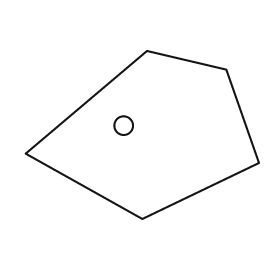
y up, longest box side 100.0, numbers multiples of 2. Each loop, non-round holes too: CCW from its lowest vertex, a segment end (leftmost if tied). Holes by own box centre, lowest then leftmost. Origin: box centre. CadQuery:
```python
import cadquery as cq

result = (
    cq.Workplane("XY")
    .moveTo(0.0, -36.0)
    .lineTo(50.0, -12.0)
    .lineTo(36.0, 28.0)
    .lineTo(2.0, 36.0)
    .lineTo(-50.0, -8.0)
    .close()
    .moveTo(-8.0, 4.0)
    .circle(4.0)
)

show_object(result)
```